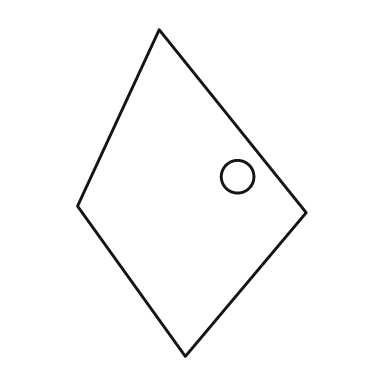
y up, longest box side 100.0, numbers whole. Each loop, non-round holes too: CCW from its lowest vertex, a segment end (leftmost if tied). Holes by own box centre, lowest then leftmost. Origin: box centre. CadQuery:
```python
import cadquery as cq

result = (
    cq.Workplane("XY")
    .moveTo(-2.0, -50.0)
    .lineTo(35.0, -6.0)
    .lineTo(-10.0, 50.0)
    .lineTo(-35.0, -4.0)
    .close()
    .moveTo(14.0, 5.0)
    .circle(5.0)
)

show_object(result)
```